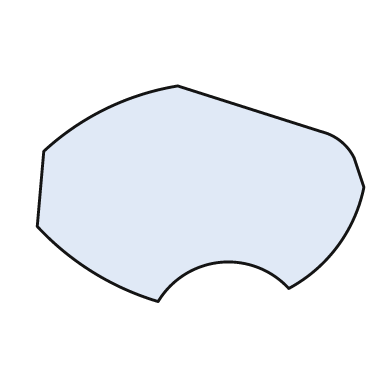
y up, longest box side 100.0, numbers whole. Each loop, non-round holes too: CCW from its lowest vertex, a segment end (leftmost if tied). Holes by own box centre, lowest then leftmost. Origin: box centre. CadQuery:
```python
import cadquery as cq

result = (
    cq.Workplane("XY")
    .moveTo(-13.0, -33.0)
    .threePointArc((6.0, -21.0), (27.0, -29.0))
    .threePointArc((42.0, -16.0), (50.0, 2.0))
    .lineTo(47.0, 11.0)
    .threePointArc((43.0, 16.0), (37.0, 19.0))
    .lineTo(-7.0, 33.0)
    .threePointArc((-29.0, 26.0), (-48.0, 13.0))
    .lineTo(-50.0, -10.0)
    .threePointArc((-33.0, -24.0), (-13.0, -33.0))
    .close()
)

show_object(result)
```